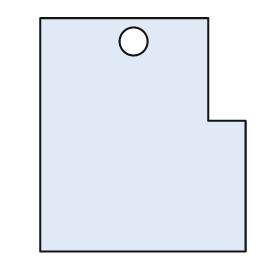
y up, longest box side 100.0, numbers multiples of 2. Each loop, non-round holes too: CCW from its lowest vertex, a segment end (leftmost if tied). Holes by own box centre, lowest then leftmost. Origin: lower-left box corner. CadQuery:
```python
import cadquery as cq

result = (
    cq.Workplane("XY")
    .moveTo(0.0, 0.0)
    .lineTo(88.0, 0.0)
    .lineTo(88.0, 56.0)
    .lineTo(72.0, 56.0)
    .lineTo(72.0, 100.0)
    .lineTo(0.0, 100.0)
    .close()
    .moveTo(40.0, 90.0)
    .circle(6.0)
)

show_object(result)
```